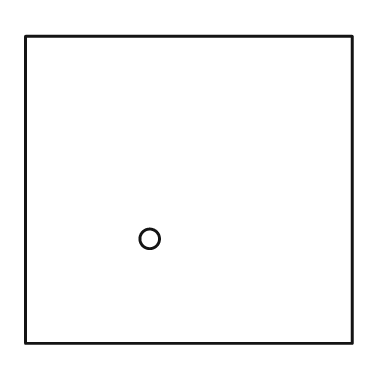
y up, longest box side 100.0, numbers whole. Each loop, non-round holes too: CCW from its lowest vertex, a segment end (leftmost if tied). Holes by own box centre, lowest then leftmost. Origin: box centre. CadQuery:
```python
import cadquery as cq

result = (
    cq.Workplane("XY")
    .moveTo(-50.0, -47.0)
    .lineTo(50.0, -47.0)
    .lineTo(50.0, 47.0)
    .lineTo(-50.0, 47.0)
    .close()
    .moveTo(-12.0, -15.0)
    .circle(3.0)
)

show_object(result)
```